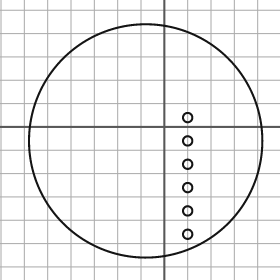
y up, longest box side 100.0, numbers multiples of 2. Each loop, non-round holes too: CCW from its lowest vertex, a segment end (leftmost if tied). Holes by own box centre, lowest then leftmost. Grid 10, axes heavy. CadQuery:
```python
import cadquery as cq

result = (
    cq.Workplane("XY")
    .moveTo(-8.0, -6.0)
    .circle(50.0)
    .moveTo(10.0, -46.0)
    .circle(2.0)
    .moveTo(10.0, -36.0)
    .circle(2.0)
    .moveTo(10.0, -26.0)
    .circle(2.0)
    .moveTo(10.0, -16.0)
    .circle(2.0)
    .moveTo(10.0, -6.0)
    .circle(2.0)
    .moveTo(10.0, 4.0)
    .circle(2.0)
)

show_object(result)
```